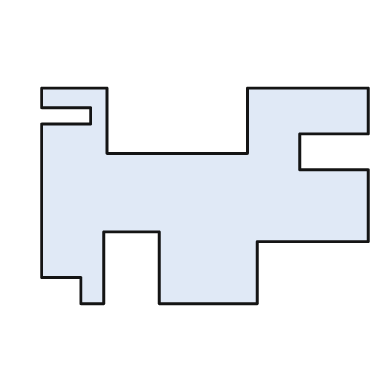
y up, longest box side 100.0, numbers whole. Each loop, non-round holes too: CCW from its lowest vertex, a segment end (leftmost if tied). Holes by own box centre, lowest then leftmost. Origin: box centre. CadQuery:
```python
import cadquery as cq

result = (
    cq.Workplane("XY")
    .moveTo(-38.0, -33.0)
    .lineTo(-31.0, -33.0)
    .lineTo(-31.0, -11.0)
    .lineTo(-14.0, -11.0)
    .lineTo(-14.0, -33.0)
    .lineTo(16.0, -33.0)
    .lineTo(16.0, -14.0)
    .lineTo(50.0, -14.0)
    .lineTo(50.0, 8.0)
    .lineTo(29.0, 8.0)
    .lineTo(29.0, 19.0)
    .lineTo(50.0, 19.0)
    .lineTo(50.0, 33.0)
    .lineTo(13.0, 33.0)
    .lineTo(13.0, 13.0)
    .lineTo(-30.0, 13.0)
    .lineTo(-30.0, 33.0)
    .lineTo(-50.0, 33.0)
    .lineTo(-50.0, 27.0)
    .lineTo(-35.0, 27.0)
    .lineTo(-35.0, 22.0)
    .lineTo(-50.0, 22.0)
    .lineTo(-50.0, -25.0)
    .lineTo(-38.0, -25.0)
    .close()
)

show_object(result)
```